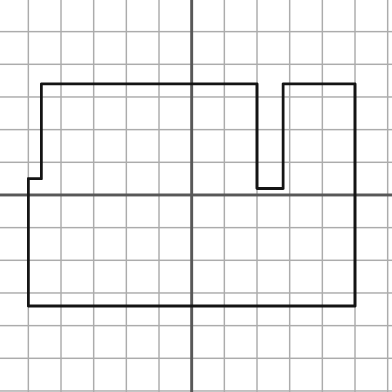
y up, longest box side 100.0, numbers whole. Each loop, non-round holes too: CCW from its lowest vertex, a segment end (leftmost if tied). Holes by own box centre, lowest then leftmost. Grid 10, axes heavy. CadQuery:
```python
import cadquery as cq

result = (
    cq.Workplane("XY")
    .moveTo(-50.0, -34.0)
    .lineTo(50.0, -34.0)
    .lineTo(50.0, 34.0)
    .lineTo(28.0, 34.0)
    .lineTo(28.0, 2.0)
    .lineTo(20.0, 2.0)
    .lineTo(20.0, 34.0)
    .lineTo(-46.0, 34.0)
    .lineTo(-46.0, 5.0)
    .lineTo(-50.0, 5.0)
    .close()
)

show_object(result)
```